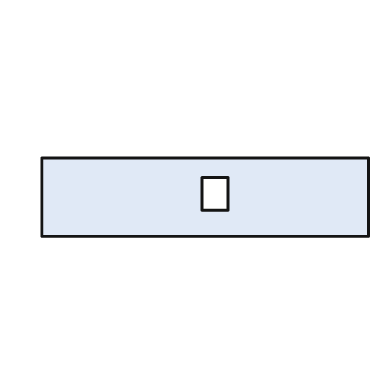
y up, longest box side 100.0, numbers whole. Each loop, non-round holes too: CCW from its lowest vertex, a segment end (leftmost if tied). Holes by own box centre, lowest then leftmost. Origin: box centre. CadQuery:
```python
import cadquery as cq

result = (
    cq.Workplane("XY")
    .moveTo(-50.0, -12.0)
    .lineTo(50.0, -12.0)
    .lineTo(50.0, 12.0)
    .lineTo(-50.0, 12.0)
    .close()
    .moveTo(-1.0, -4.0)
    .lineTo(7.0, -4.0)
    .lineTo(7.0, 6.0)
    .lineTo(-1.0, 6.0)
    .close()
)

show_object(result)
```